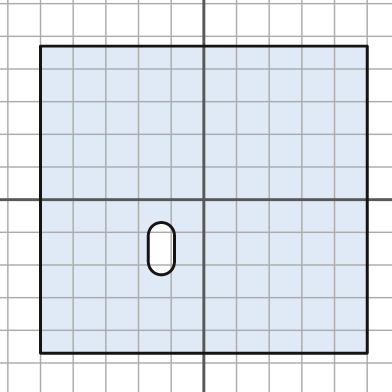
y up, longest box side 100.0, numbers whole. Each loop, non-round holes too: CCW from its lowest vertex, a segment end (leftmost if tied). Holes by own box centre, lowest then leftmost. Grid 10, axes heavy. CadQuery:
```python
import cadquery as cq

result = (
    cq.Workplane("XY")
    .moveTo(-50.0, -47.0)
    .lineTo(50.0, -47.0)
    .lineTo(50.0, 47.0)
    .lineTo(-50.0, 47.0)
    .close()
    .moveTo(-17.0, -19.0)
    .threePointArc((-13.0, -23.0), (-9.0, -19.0))
    .lineTo(-9.0, -11.0)
    .threePointArc((-13.0, -7.0), (-17.0, -11.0))
    .close()
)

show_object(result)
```